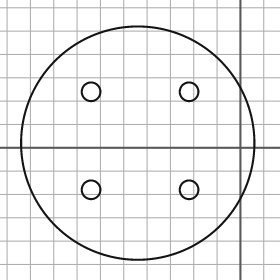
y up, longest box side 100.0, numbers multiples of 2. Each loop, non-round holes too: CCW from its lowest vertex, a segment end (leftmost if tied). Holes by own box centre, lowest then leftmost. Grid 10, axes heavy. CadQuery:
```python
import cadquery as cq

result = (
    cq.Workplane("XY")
    .moveTo(-44.0, 2.0)
    .circle(50.0)
    .moveTo(-64.0, -18.0)
    .circle(4.0)
    .moveTo(-22.0, -18.0)
    .circle(4.0)
    .moveTo(-64.0, 24.0)
    .circle(4.0)
    .moveTo(-22.0, 24.0)
    .circle(4.0)
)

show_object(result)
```